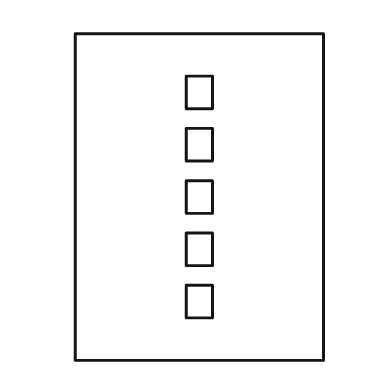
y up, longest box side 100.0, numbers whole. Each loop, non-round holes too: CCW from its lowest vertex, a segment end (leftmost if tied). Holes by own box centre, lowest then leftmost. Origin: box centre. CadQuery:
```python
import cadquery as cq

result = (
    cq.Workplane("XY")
    .moveTo(-38.0, -50.0)
    .lineTo(38.0, -50.0)
    .lineTo(38.0, 50.0)
    .lineTo(-38.0, 50.0)
    .close()
    .moveTo(-4.0, -37.0)
    .lineTo(4.0, -37.0)
    .lineTo(4.0, -27.0)
    .lineTo(-4.0, -27.0)
    .close()
    .moveTo(-4.0, -21.0)
    .lineTo(4.0, -21.0)
    .lineTo(4.0, -11.0)
    .lineTo(-4.0, -11.0)
    .close()
    .moveTo(-4.0, -5.0)
    .lineTo(4.0, -5.0)
    .lineTo(4.0, 5.0)
    .lineTo(-4.0, 5.0)
    .close()
    .moveTo(-4.0, 11.0)
    .lineTo(4.0, 11.0)
    .lineTo(4.0, 21.0)
    .lineTo(-4.0, 21.0)
    .close()
    .moveTo(-4.0, 27.0)
    .lineTo(4.0, 27.0)
    .lineTo(4.0, 37.0)
    .lineTo(-4.0, 37.0)
    .close()
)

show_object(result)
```